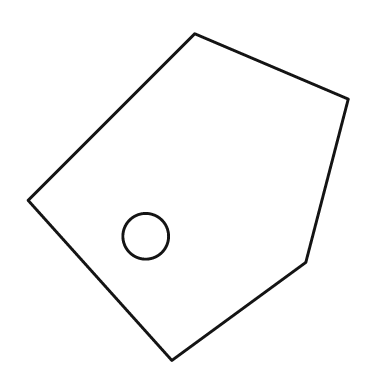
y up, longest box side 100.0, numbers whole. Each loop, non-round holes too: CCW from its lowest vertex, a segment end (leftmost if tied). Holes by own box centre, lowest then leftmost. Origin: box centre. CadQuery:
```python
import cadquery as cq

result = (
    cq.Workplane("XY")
    .moveTo(-5.0, -50.0)
    .lineTo(36.0, -20.0)
    .lineTo(49.0, 30.0)
    .lineTo(2.0, 50.0)
    .lineTo(-49.0, -1.0)
    .close()
    .moveTo(-13.0, -12.0)
    .circle(7.0)
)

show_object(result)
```